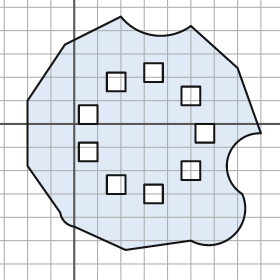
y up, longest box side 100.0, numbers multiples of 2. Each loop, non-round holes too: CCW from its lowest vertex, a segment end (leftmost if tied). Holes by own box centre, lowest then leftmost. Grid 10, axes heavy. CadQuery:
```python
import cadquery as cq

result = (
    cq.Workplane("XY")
    .moveTo(22.0, -54.0)
    .lineTo(50.0, -50.0)
    .threePointArc((68.0, -48.0), (72.0, -30.0))
    .threePointArc((66.0, -14.0), (80.0, -4.0))
    .lineTo(70.0, 24.0)
    .lineTo(50.0, 42.0)
    .threePointArc((34.0, 38.0), (20.0, 46.0))
    .lineTo(-4.0, 34.0)
    .lineTo(-20.0, 10.0)
    .lineTo(-20.0, -18.0)
    .lineTo(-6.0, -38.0)
    .threePointArc((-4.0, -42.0), (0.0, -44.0))
    .close()
    .moveTo(30.0, -34.0)
    .lineTo(38.0, -34.0)
    .lineTo(38.0, -26.0)
    .lineTo(30.0, -26.0)
    .close()
    .moveTo(14.0, -30.0)
    .lineTo(22.0, -30.0)
    .lineTo(22.0, -22.0)
    .lineTo(14.0, -22.0)
    .close()
    .moveTo(46.0, -24.0)
    .lineTo(54.0, -24.0)
    .lineTo(54.0, -16.0)
    .lineTo(46.0, -16.0)
    .close()
    .moveTo(2.0, -16.0)
    .lineTo(10.0, -16.0)
    .lineTo(10.0, -8.0)
    .lineTo(2.0, -8.0)
    .close()
    .moveTo(52.0, -8.0)
    .lineTo(60.0, -8.0)
    .lineTo(60.0, 0.0)
    .lineTo(52.0, 0.0)
    .close()
    .moveTo(2.0, 0.0)
    .lineTo(10.0, 0.0)
    .lineTo(10.0, 8.0)
    .lineTo(2.0, 8.0)
    .close()
    .moveTo(46.0, 8.0)
    .lineTo(54.0, 8.0)
    .lineTo(54.0, 16.0)
    .lineTo(46.0, 16.0)
    .close()
    .moveTo(14.0, 14.0)
    .lineTo(22.0, 14.0)
    .lineTo(22.0, 22.0)
    .lineTo(14.0, 22.0)
    .close()
    .moveTo(30.0, 18.0)
    .lineTo(38.0, 18.0)
    .lineTo(38.0, 26.0)
    .lineTo(30.0, 26.0)
    .close()
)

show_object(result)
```